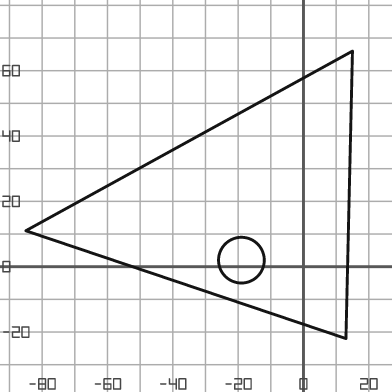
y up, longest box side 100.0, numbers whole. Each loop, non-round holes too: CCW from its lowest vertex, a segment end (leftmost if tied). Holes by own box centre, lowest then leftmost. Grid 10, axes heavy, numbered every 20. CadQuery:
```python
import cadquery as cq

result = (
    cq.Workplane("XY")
    .moveTo(13.0, -22.0)
    .lineTo(15.0, 66.0)
    .lineTo(-85.0, 11.0)
    .close()
    .moveTo(-19.0, 2.0)
    .circle(7.0)
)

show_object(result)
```